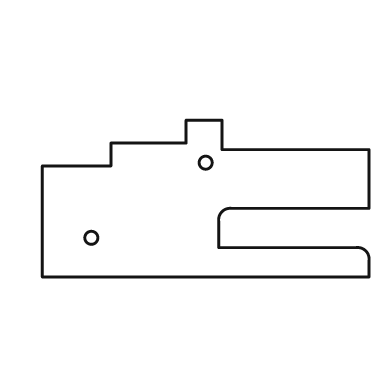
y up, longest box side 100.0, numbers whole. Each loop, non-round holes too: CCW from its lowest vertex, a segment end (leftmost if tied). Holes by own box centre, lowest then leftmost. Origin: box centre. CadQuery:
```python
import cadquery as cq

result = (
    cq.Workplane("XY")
    .moveTo(-50.0, -24.0)
    .lineTo(50.0, -24.0)
    .lineTo(50.0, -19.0)
    .threePointArc((49.0, -16.0), (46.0, -15.0))
    .lineTo(4.0, -15.0)
    .lineTo(4.0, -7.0)
    .threePointArc((5.0, -4.0), (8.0, -3.0))
    .lineTo(50.0, -3.0)
    .lineTo(50.0, 15.0)
    .lineTo(5.0, 15.0)
    .lineTo(5.0, 24.0)
    .lineTo(-6.0, 24.0)
    .lineTo(-6.0, 17.0)
    .lineTo(-29.0, 17.0)
    .lineTo(-29.0, 10.0)
    .lineTo(-50.0, 10.0)
    .close()
    .moveTo(-35.0, -12.0)
    .circle(2.0)
    .moveTo(0.0, 11.0)
    .circle(2.0)
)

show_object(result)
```